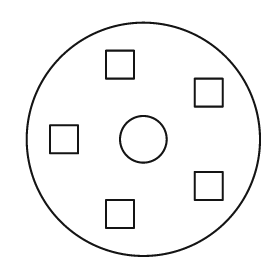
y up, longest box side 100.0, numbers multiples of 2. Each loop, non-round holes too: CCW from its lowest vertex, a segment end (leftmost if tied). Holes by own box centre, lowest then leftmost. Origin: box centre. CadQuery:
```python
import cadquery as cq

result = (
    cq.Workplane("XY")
    .moveTo(0.0, 0.0)
    .circle(50.0)
    .moveTo(-16.0, -38.0)
    .lineTo(-4.0, -38.0)
    .lineTo(-4.0, -26.0)
    .lineTo(-16.0, -26.0)
    .close()
    .moveTo(22.0, -26.0)
    .lineTo(34.0, -26.0)
    .lineTo(34.0, -14.0)
    .lineTo(22.0, -14.0)
    .close()
    .moveTo(-40.0, -6.0)
    .lineTo(-28.0, -6.0)
    .lineTo(-28.0, 6.0)
    .lineTo(-40.0, 6.0)
    .close()
    .moveTo(0.0, 0.0)
    .circle(10.0)
    .moveTo(22.0, 14.0)
    .lineTo(34.0, 14.0)
    .lineTo(34.0, 26.0)
    .lineTo(22.0, 26.0)
    .close()
    .moveTo(-16.0, 26.0)
    .lineTo(-4.0, 26.0)
    .lineTo(-4.0, 38.0)
    .lineTo(-16.0, 38.0)
    .close()
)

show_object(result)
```